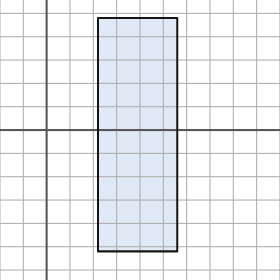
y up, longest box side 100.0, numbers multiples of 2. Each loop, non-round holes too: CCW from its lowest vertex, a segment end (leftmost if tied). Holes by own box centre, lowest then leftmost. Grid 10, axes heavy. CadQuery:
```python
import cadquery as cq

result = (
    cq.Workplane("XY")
    .moveTo(22.0, -52.0)
    .lineTo(56.0, -52.0)
    .lineTo(56.0, 48.0)
    .lineTo(22.0, 48.0)
    .close()
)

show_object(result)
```